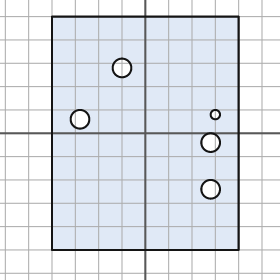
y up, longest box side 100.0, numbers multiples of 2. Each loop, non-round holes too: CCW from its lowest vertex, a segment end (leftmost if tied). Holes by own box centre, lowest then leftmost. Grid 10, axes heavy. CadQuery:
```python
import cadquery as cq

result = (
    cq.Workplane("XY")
    .moveTo(-40.0, -50.0)
    .lineTo(40.0, -50.0)
    .lineTo(40.0, 50.0)
    .lineTo(-40.0, 50.0)
    .close()
    .moveTo(28.0, -24.0)
    .circle(4.0)
    .moveTo(28.0, -4.0)
    .circle(4.0)
    .moveTo(-28.0, 6.0)
    .circle(4.0)
    .moveTo(30.0, 8.0)
    .circle(2.0)
    .moveTo(-10.0, 28.0)
    .circle(4.0)
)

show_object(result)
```